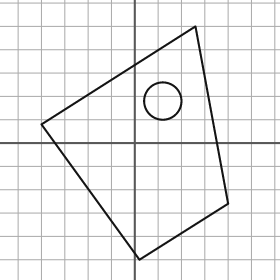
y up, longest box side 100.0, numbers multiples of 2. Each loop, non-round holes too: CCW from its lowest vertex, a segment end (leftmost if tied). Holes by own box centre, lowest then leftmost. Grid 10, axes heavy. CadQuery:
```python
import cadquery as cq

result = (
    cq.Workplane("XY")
    .moveTo(2.0, -50.0)
    .lineTo(40.0, -26.0)
    .lineTo(26.0, 50.0)
    .lineTo(-40.0, 8.0)
    .close()
    .moveTo(12.0, 18.0)
    .circle(8.0)
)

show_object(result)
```